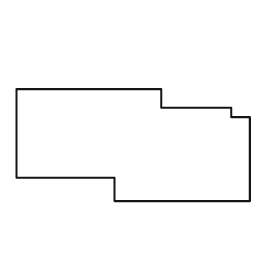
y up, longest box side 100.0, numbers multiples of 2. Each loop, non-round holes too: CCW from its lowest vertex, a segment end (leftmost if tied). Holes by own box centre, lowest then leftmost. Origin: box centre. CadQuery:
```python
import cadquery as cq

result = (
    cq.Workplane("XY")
    .moveTo(-8.0, -24.0)
    .lineTo(50.0, -24.0)
    .lineTo(50.0, 12.0)
    .lineTo(42.0, 12.0)
    .lineTo(42.0, 16.0)
    .lineTo(12.0, 16.0)
    .lineTo(12.0, 24.0)
    .lineTo(-50.0, 24.0)
    .lineTo(-50.0, -14.0)
    .lineTo(-8.0, -14.0)
    .close()
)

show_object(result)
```